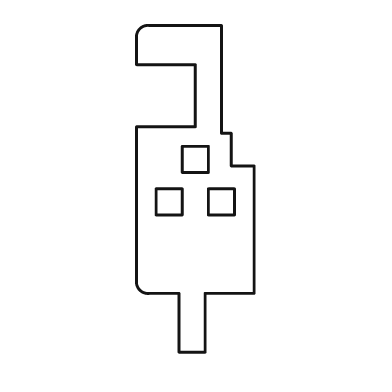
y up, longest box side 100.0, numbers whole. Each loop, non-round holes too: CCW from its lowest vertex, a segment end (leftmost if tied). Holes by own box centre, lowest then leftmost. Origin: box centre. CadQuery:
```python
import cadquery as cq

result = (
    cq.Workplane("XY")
    .moveTo(-5.0, -50.0)
    .lineTo(3.0, -50.0)
    .lineTo(3.0, -32.0)
    .lineTo(18.0, -32.0)
    .lineTo(18.0, 7.0)
    .lineTo(11.0, 7.0)
    .lineTo(11.0, 17.0)
    .lineTo(8.0, 17.0)
    .lineTo(8.0, 50.0)
    .lineTo(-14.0, 50.0)
    .threePointArc((-17.0, 49.0), (-18.0, 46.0))
    .lineTo(-18.0, 38.0)
    .lineTo(0.0, 38.0)
    .lineTo(0.0, 19.0)
    .lineTo(-18.0, 19.0)
    .lineTo(-18.0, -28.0)
    .threePointArc((-17.0, -31.0), (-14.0, -32.0))
    .lineTo(-5.0, -32.0)
    .close()
    .moveTo(-12.0, -8.0)
    .lineTo(-4.0, -8.0)
    .lineTo(-4.0, 0.0)
    .lineTo(-12.0, 0.0)
    .close()
    .moveTo(4.0, -8.0)
    .lineTo(12.0, -8.0)
    .lineTo(12.0, 0.0)
    .lineTo(4.0, 0.0)
    .close()
    .moveTo(-4.0, 5.0)
    .lineTo(4.0, 5.0)
    .lineTo(4.0, 13.0)
    .lineTo(-4.0, 13.0)
    .close()
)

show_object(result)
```